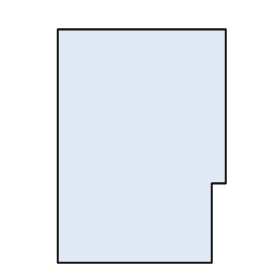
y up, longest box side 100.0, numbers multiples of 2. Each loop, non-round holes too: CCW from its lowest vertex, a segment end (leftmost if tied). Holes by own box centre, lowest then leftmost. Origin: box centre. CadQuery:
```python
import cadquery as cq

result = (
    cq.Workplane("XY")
    .moveTo(-36.0, -50.0)
    .lineTo(30.0, -50.0)
    .lineTo(30.0, -16.0)
    .lineTo(36.0, -16.0)
    .lineTo(36.0, 50.0)
    .lineTo(-36.0, 50.0)
    .close()
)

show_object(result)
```